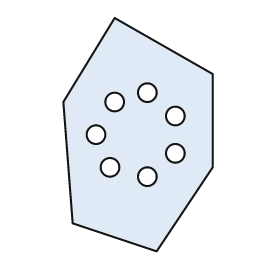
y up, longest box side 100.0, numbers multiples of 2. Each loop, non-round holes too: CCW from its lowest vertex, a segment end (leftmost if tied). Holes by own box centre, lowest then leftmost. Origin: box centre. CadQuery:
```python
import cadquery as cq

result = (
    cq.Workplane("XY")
    .moveTo(8.0, -50.0)
    .lineTo(32.0, -14.0)
    .lineTo(32.0, 26.0)
    .lineTo(-10.0, 50.0)
    .lineTo(-32.0, 14.0)
    .lineTo(-28.0, -38.0)
    .close()
    .moveTo(4.0, -18.0)
    .circle(4.0)
    .moveTo(-12.0, -14.0)
    .circle(4.0)
    .moveTo(16.0, -8.0)
    .circle(4.0)
    .moveTo(-18.0, 0.0)
    .circle(4.0)
    .moveTo(16.0, 8.0)
    .circle(4.0)
    .moveTo(-10.0, 14.0)
    .circle(4.0)
    .moveTo(4.0, 18.0)
    .circle(4.0)
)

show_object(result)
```